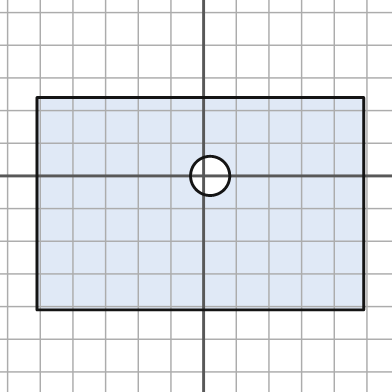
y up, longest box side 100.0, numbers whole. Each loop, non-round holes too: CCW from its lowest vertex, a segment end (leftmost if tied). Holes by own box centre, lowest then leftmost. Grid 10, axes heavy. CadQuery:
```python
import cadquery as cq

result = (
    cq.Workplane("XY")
    .moveTo(-51.0, -41.0)
    .lineTo(49.0, -41.0)
    .lineTo(49.0, 24.0)
    .lineTo(-51.0, 24.0)
    .close()
    .moveTo(2.0, 0.0)
    .circle(6.0)
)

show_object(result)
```